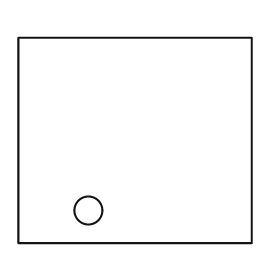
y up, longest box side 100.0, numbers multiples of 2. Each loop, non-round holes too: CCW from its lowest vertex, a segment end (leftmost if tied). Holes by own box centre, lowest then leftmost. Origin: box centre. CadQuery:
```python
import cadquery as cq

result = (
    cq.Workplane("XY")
    .moveTo(-50.0, -44.0)
    .lineTo(50.0, -44.0)
    .lineTo(50.0, 44.0)
    .lineTo(-50.0, 44.0)
    .close()
    .moveTo(-20.0, -30.0)
    .circle(6.0)
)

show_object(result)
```